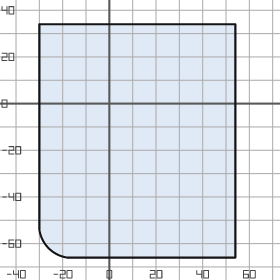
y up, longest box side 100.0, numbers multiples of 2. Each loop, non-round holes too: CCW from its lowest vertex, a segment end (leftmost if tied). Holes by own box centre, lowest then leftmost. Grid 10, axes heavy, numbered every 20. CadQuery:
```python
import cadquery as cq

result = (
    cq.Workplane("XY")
    .moveTo(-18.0, -66.0)
    .lineTo(54.0, -66.0)
    .lineTo(54.0, 34.0)
    .lineTo(-30.0, 34.0)
    .lineTo(-30.0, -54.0)
    .threePointArc((-26.0, -62.0), (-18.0, -66.0))
    .close()
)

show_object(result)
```